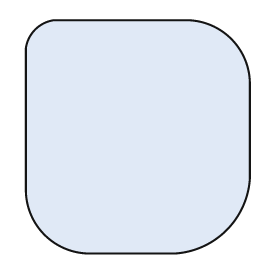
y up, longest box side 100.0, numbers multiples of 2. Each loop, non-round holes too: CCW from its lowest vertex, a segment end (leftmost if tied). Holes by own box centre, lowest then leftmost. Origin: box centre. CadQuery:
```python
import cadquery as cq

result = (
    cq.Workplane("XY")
    .moveTo(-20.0, -50.0)
    .lineTo(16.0, -50.0)
    .threePointArc((38.0, -40.0), (48.0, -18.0))
    .lineTo(48.0, 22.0)
    .threePointArc((40.0, 42.0), (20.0, 50.0))
    .lineTo(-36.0, 50.0)
    .threePointArc((-44.0, 46.0), (-48.0, 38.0))
    .lineTo(-48.0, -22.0)
    .threePointArc((-40.0, -42.0), (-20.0, -50.0))
    .close()
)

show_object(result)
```